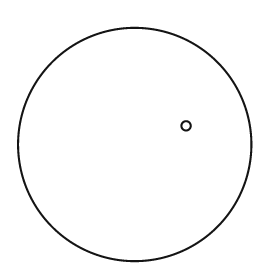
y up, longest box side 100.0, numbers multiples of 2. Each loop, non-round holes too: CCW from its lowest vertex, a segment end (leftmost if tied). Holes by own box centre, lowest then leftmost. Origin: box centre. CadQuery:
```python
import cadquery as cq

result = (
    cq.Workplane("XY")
    .moveTo(0.0, 0.0)
    .circle(50.0)
    .moveTo(22.0, 8.0)
    .circle(2.0)
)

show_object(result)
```